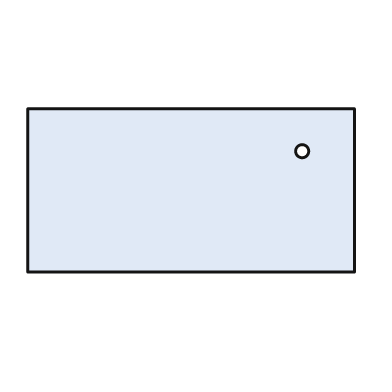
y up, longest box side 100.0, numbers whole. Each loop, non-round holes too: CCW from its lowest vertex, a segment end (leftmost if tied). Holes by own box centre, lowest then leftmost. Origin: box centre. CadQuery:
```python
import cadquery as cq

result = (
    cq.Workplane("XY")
    .moveTo(-50.0, -25.0)
    .lineTo(50.0, -25.0)
    .lineTo(50.0, 25.0)
    .lineTo(-50.0, 25.0)
    .close()
    .moveTo(34.0, 12.0)
    .circle(2.0)
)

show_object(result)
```